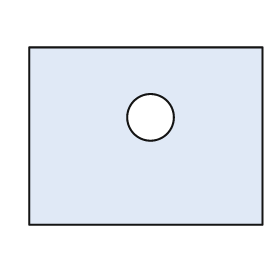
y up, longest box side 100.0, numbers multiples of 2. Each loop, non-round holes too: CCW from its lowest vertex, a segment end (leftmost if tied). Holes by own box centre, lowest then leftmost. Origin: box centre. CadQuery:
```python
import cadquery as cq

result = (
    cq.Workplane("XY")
    .moveTo(-50.0, -38.0)
    .lineTo(50.0, -38.0)
    .lineTo(50.0, 38.0)
    .lineTo(-50.0, 38.0)
    .close()
    .moveTo(2.0, 8.0)
    .circle(10.0)
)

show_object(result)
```